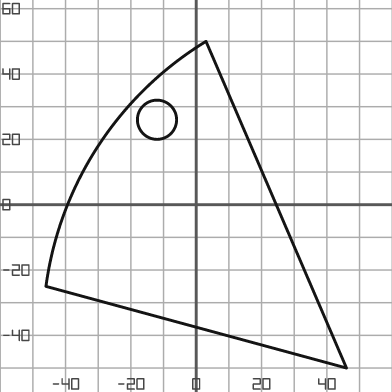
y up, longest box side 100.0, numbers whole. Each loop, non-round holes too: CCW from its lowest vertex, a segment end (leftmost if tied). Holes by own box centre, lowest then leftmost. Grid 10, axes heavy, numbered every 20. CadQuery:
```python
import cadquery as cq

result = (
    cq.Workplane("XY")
    .moveTo(46.0, -50.0)
    .lineTo(3.0, 50.0)
    .threePointArc((-30.0, 18.0), (-46.0, -25.0))
    .close()
    .moveTo(-12.0, 26.0)
    .circle(6.0)
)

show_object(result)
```